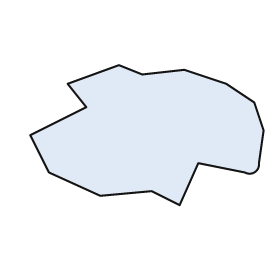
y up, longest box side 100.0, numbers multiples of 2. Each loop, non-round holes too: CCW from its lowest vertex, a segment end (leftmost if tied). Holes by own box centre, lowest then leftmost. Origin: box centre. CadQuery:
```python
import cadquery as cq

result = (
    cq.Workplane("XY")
    .moveTo(14.0, -30.0)
    .lineTo(22.0, -12.0)
    .lineTo(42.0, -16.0)
    .threePointArc((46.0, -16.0), (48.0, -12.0))
    .lineTo(50.0, 2.0)
    .lineTo(46.0, 14.0)
    .lineTo(34.0, 22.0)
    .lineTo(16.0, 28.0)
    .lineTo(-2.0, 26.0)
    .lineTo(-12.0, 30.0)
    .lineTo(-34.0, 22.0)
    .lineTo(-26.0, 12.0)
    .lineTo(-50.0, 0.0)
    .lineTo(-42.0, -16.0)
    .lineTo(-20.0, -26.0)
    .lineTo(2.0, -24.0)
    .close()
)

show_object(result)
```